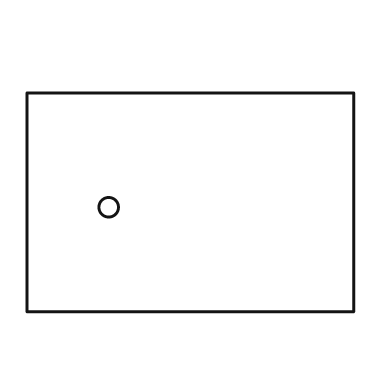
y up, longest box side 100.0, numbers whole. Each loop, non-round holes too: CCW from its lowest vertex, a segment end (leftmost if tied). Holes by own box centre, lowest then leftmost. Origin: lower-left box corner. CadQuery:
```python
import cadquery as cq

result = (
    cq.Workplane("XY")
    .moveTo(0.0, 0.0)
    .lineTo(100.0, 0.0)
    .lineTo(100.0, 67.0)
    .lineTo(0.0, 67.0)
    .close()
    .moveTo(25.0, 32.0)
    .circle(3.0)
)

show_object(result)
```